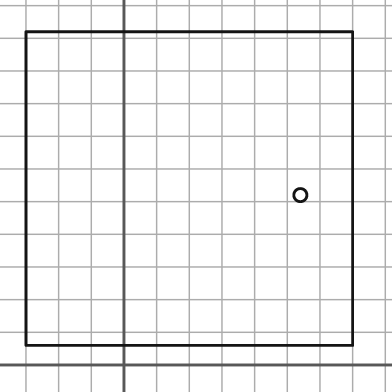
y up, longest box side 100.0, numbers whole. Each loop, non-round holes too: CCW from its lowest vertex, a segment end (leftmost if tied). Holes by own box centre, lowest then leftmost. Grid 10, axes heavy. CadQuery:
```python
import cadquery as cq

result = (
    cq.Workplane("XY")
    .moveTo(-30.0, 6.0)
    .lineTo(70.0, 6.0)
    .lineTo(70.0, 102.0)
    .lineTo(-30.0, 102.0)
    .close()
    .moveTo(54.0, 52.0)
    .circle(2.0)
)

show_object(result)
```